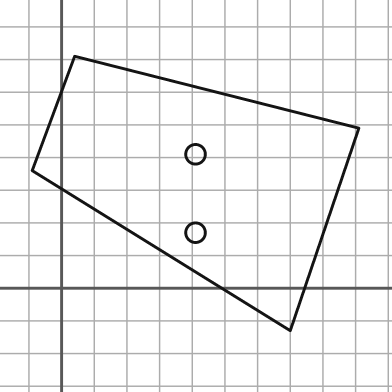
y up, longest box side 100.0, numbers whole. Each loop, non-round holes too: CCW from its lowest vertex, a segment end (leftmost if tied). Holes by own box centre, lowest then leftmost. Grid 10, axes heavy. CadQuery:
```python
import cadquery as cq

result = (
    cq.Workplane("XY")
    .moveTo(70.0, -13.0)
    .lineTo(91.0, 49.0)
    .lineTo(4.0, 71.0)
    .lineTo(-9.0, 36.0)
    .close()
    .moveTo(41.0, 17.0)
    .circle(3.0)
    .moveTo(41.0, 41.0)
    .circle(3.0)
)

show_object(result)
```